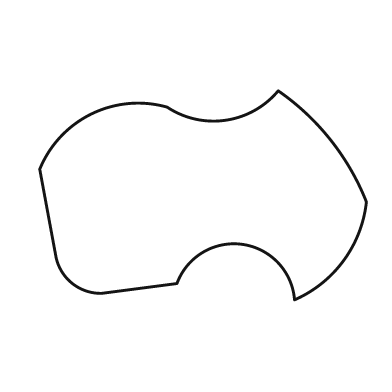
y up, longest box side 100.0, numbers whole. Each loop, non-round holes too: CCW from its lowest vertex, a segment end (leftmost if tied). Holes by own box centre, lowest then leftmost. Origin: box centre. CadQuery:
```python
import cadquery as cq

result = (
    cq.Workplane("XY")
    .moveTo(28.0, -32.0)
    .threePointArc((43.0, -20.0), (50.0, -2.0))
    .threePointArc((39.0, 17.0), (23.0, 32.0))
    .threePointArc((7.0, 23.0), (-11.0, 27.0))
    .threePointArc((-34.0, 25.0), (-50.0, 8.0))
    .lineTo(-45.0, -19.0)
    .threePointArc((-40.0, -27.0), (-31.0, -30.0))
    .lineTo(-8.0, -27.0)
    .threePointArc((12.0, -15.0), (28.0, -32.0))
    .close()
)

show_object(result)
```